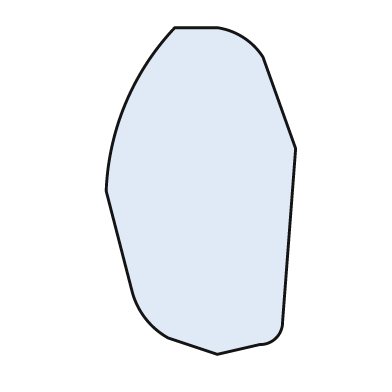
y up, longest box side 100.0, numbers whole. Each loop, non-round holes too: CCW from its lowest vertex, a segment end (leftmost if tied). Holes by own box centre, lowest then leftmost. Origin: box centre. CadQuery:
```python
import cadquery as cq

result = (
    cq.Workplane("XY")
    .moveTo(5.0, -50.0)
    .lineTo(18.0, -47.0)
    .threePointArc((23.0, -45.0), (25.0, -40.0))
    .lineTo(29.0, 13.0)
    .lineTo(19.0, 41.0)
    .threePointArc((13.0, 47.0), (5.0, 50.0))
    .lineTo(-8.0, 50.0)
    .threePointArc((-23.0, 27.0), (-29.0, 0.0))
    .lineTo(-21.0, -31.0)
    .threePointArc((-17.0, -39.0), (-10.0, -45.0))
    .close()
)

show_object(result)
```